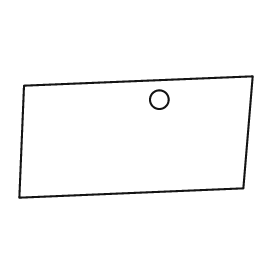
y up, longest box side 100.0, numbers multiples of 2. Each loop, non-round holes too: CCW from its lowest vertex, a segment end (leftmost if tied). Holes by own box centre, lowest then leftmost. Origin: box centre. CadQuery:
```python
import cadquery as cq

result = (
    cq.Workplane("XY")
    .moveTo(-50.0, -26.0)
    .lineTo(46.0, -22.0)
    .lineTo(50.0, 26.0)
    .lineTo(-48.0, 22.0)
    .close()
    .moveTo(10.0, 16.0)
    .circle(4.0)
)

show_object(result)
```